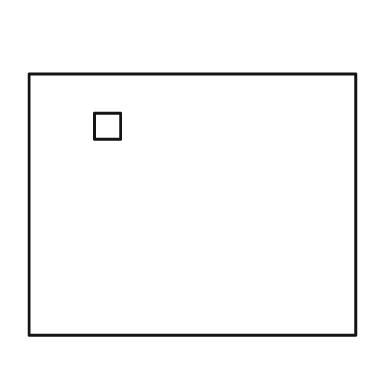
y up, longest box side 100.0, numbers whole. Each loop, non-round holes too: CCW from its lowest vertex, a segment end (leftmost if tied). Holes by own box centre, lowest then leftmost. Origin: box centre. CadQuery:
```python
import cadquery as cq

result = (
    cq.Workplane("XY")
    .moveTo(-50.0, -40.0)
    .lineTo(50.0, -40.0)
    .lineTo(50.0, 40.0)
    .lineTo(-50.0, 40.0)
    .close()
    .moveTo(-30.0, 20.0)
    .lineTo(-22.0, 20.0)
    .lineTo(-22.0, 28.0)
    .lineTo(-30.0, 28.0)
    .close()
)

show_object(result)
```